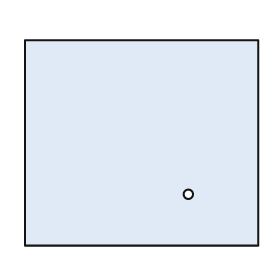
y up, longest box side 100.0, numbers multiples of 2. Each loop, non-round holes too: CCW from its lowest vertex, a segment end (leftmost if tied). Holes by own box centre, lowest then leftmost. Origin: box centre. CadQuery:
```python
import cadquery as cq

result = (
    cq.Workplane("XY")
    .moveTo(-50.0, -44.0)
    .lineTo(50.0, -44.0)
    .lineTo(50.0, 44.0)
    .lineTo(-50.0, 44.0)
    .close()
    .moveTo(20.0, -22.0)
    .circle(2.0)
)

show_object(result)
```